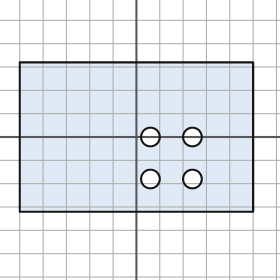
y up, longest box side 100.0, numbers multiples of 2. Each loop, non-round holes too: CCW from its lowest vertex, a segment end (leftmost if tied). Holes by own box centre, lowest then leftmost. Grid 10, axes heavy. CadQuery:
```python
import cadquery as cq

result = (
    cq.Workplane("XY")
    .moveTo(-50.0, -32.0)
    .lineTo(50.0, -32.0)
    .lineTo(50.0, 32.0)
    .lineTo(-50.0, 32.0)
    .close()
    .moveTo(6.0, -18.0)
    .circle(4.0)
    .moveTo(24.0, -18.0)
    .circle(4.0)
    .moveTo(6.0, 0.0)
    .circle(4.0)
    .moveTo(24.0, 0.0)
    .circle(4.0)
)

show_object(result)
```